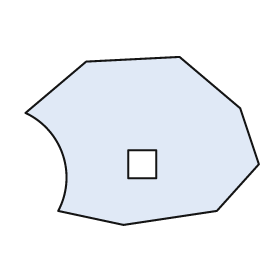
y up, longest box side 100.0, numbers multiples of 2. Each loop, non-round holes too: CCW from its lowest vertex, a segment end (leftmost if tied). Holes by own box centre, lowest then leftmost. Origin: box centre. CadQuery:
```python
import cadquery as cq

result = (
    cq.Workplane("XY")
    .moveTo(-8.0, -36.0)
    .lineTo(32.0, -30.0)
    .lineTo(50.0, -10.0)
    .lineTo(42.0, 14.0)
    .lineTo(16.0, 36.0)
    .lineTo(-24.0, 34.0)
    .lineTo(-50.0, 12.0)
    .threePointArc((-34.0, -6.0), (-36.0, -30.0))
    .close()
    .moveTo(-6.0, -16.0)
    .lineTo(6.0, -16.0)
    .lineTo(6.0, -4.0)
    .lineTo(-6.0, -4.0)
    .close()
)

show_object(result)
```